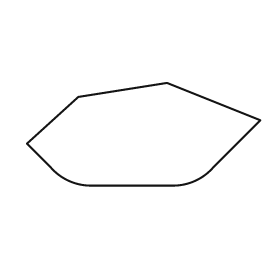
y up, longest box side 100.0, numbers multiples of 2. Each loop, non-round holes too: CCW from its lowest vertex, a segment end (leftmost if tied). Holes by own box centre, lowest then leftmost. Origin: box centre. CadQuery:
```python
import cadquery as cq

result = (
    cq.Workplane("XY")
    .moveTo(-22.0, -22.0)
    .lineTo(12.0, -22.0)
    .threePointArc((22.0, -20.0), (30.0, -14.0))
    .lineTo(50.0, 6.0)
    .lineTo(10.0, 22.0)
    .lineTo(-28.0, 16.0)
    .lineTo(-50.0, -4.0)
    .lineTo(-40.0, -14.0)
    .threePointArc((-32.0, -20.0), (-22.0, -22.0))
    .close()
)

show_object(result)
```